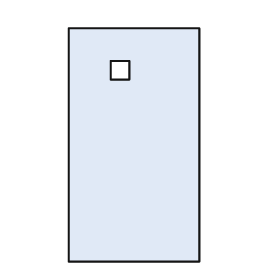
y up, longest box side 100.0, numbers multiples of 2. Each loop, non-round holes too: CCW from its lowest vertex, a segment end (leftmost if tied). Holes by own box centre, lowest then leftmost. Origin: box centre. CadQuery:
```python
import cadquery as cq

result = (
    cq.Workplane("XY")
    .moveTo(-28.0, -50.0)
    .lineTo(28.0, -50.0)
    .lineTo(28.0, 50.0)
    .lineTo(-28.0, 50.0)
    .close()
    .moveTo(-10.0, 28.0)
    .lineTo(-2.0, 28.0)
    .lineTo(-2.0, 36.0)
    .lineTo(-10.0, 36.0)
    .close()
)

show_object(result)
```